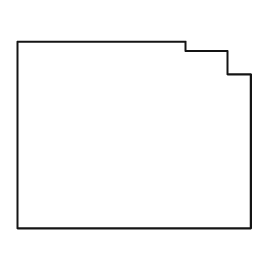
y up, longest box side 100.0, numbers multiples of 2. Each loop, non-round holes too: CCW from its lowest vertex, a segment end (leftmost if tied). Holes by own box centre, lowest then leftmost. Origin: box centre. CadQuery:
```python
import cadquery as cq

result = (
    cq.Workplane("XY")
    .moveTo(-50.0, -40.0)
    .lineTo(50.0, -40.0)
    .lineTo(50.0, 26.0)
    .lineTo(40.0, 26.0)
    .lineTo(40.0, 36.0)
    .lineTo(22.0, 36.0)
    .lineTo(22.0, 40.0)
    .lineTo(-50.0, 40.0)
    .close()
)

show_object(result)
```